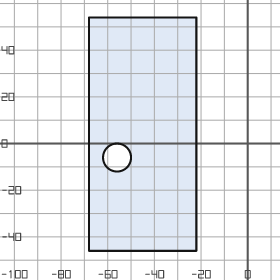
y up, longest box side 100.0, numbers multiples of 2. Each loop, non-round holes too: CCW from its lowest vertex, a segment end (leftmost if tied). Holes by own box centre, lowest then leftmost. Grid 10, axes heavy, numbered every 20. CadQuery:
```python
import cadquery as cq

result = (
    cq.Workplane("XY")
    .moveTo(-68.0, -46.0)
    .lineTo(-22.0, -46.0)
    .lineTo(-22.0, 54.0)
    .lineTo(-68.0, 54.0)
    .close()
    .moveTo(-56.0, -6.0)
    .circle(6.0)
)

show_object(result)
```